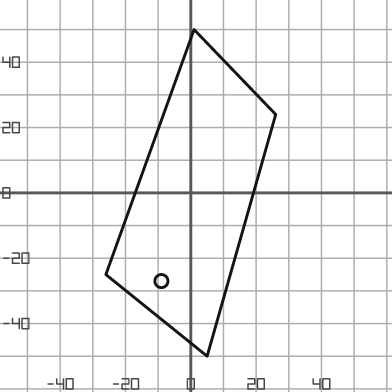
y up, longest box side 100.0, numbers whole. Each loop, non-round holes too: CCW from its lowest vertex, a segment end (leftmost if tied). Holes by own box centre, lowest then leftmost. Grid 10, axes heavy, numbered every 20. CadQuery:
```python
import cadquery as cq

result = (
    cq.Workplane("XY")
    .moveTo(5.0, -50.0)
    .lineTo(26.0, 24.0)
    .lineTo(1.0, 50.0)
    .lineTo(-26.0, -25.0)
    .close()
    .moveTo(-9.0, -27.0)
    .circle(2.0)
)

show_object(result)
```